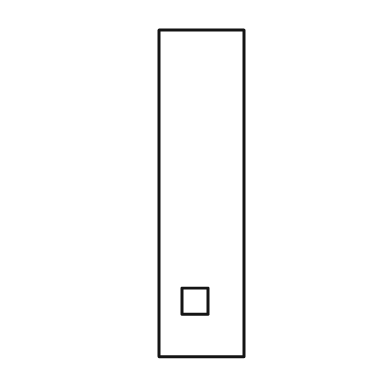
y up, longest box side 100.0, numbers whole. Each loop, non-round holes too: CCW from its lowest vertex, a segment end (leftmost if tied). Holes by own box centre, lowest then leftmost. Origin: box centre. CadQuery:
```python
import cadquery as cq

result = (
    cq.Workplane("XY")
    .moveTo(-13.0, -50.0)
    .lineTo(13.0, -50.0)
    .lineTo(13.0, 50.0)
    .lineTo(-13.0, 50.0)
    .close()
    .moveTo(-6.0, -37.0)
    .lineTo(2.0, -37.0)
    .lineTo(2.0, -29.0)
    .lineTo(-6.0, -29.0)
    .close()
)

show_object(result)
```